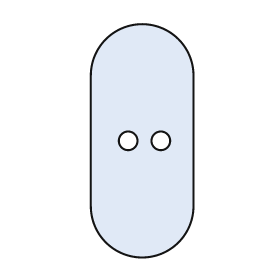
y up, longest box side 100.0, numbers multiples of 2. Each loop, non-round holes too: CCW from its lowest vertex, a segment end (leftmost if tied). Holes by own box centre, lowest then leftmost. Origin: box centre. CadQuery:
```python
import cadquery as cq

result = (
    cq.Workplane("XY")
    .moveTo(-22.0, -28.0)
    .threePointArc((0.0, -50.0), (22.0, -28.0))
    .lineTo(22.0, 28.0)
    .threePointArc((0.0, 50.0), (-22.0, 28.0))
    .close()
    .moveTo(-6.0, 0.0)
    .circle(4.0)
    .moveTo(8.0, 0.0)
    .circle(4.0)
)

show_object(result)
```